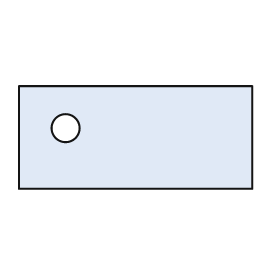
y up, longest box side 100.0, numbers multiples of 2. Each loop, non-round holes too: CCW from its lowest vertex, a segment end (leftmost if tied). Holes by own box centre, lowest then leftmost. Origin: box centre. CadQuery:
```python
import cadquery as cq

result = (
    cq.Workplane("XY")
    .moveTo(-50.0, -22.0)
    .lineTo(50.0, -22.0)
    .lineTo(50.0, 22.0)
    .lineTo(-50.0, 22.0)
    .close()
    .moveTo(-30.0, 4.0)
    .circle(6.0)
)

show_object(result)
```